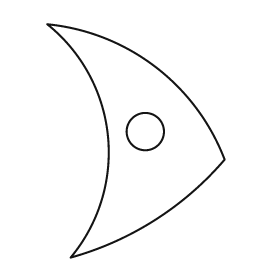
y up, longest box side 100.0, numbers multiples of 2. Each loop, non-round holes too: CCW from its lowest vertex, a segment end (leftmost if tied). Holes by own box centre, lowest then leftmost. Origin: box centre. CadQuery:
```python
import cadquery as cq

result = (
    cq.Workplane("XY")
    .moveTo(-28.0, -50.0)
    .threePointArc((8.0, -34.0), (38.0, -8.0))
    .threePointArc((8.0, 32.0), (-38.0, 50.0))
    .threePointArc((-12.0, 2.0), (-28.0, -50.0))
    .close()
    .moveTo(4.0, 4.0)
    .circle(8.0)
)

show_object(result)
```